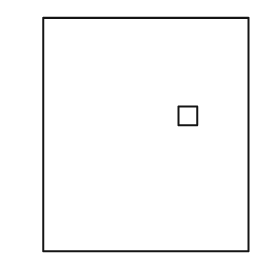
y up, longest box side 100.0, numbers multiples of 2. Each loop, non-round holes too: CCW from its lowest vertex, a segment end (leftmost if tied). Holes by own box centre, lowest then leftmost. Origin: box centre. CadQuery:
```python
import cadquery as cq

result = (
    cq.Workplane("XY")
    .moveTo(-44.0, -50.0)
    .lineTo(44.0, -50.0)
    .lineTo(44.0, 50.0)
    .lineTo(-44.0, 50.0)
    .close()
    .moveTo(14.0, 4.0)
    .lineTo(22.0, 4.0)
    .lineTo(22.0, 12.0)
    .lineTo(14.0, 12.0)
    .close()
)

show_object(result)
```